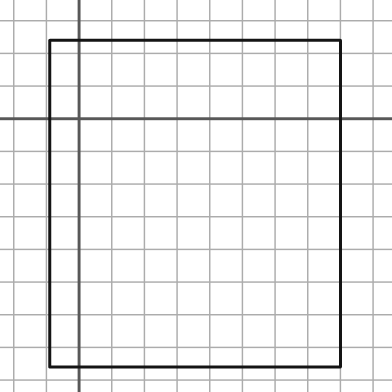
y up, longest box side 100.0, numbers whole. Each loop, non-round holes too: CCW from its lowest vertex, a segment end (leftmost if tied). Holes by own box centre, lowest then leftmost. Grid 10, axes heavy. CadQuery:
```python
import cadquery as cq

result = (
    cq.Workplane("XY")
    .moveTo(-9.0, -76.0)
    .lineTo(80.0, -76.0)
    .lineTo(80.0, 24.0)
    .lineTo(-9.0, 24.0)
    .close()
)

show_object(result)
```